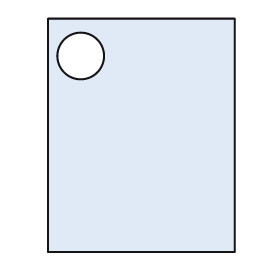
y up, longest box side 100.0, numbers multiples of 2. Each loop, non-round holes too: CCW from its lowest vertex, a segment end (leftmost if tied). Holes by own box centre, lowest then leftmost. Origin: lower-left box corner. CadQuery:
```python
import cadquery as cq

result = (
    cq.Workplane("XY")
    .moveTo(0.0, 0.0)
    .lineTo(80.0, 0.0)
    .lineTo(80.0, 100.0)
    .lineTo(0.0, 100.0)
    .close()
    .moveTo(14.0, 84.0)
    .circle(10.0)
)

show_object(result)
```